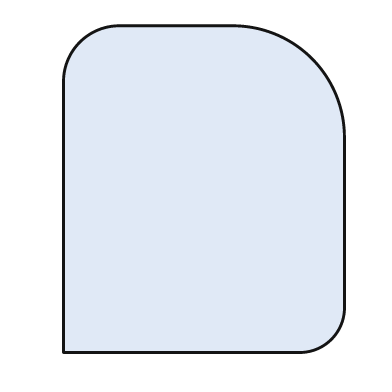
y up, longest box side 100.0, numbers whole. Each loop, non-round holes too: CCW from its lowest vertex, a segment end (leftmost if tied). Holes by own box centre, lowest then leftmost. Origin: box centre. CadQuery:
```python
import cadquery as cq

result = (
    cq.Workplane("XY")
    .moveTo(-43.0, -50.0)
    .lineTo(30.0, -50.0)
    .threePointArc((39.0, -46.0), (43.0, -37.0))
    .lineTo(43.0, 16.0)
    .threePointArc((33.0, 40.0), (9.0, 50.0))
    .lineTo(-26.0, 50.0)
    .threePointArc((-38.0, 45.0), (-43.0, 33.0))
    .close()
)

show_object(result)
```